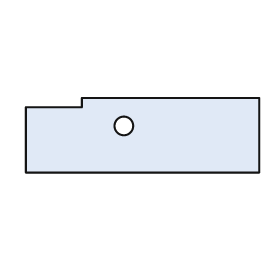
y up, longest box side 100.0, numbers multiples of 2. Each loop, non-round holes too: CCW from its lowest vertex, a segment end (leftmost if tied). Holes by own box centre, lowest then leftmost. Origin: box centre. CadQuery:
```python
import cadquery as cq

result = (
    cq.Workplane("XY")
    .moveTo(-50.0, -16.0)
    .lineTo(50.0, -16.0)
    .lineTo(50.0, 16.0)
    .lineTo(-26.0, 16.0)
    .lineTo(-26.0, 12.0)
    .lineTo(-50.0, 12.0)
    .close()
    .moveTo(-8.0, 4.0)
    .circle(4.0)
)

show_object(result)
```